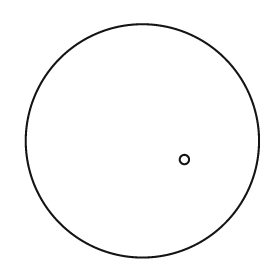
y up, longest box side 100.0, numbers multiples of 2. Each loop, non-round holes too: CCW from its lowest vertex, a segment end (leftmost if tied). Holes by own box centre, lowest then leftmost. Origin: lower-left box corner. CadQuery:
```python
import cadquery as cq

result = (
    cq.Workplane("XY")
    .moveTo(50.0, 50.0)
    .circle(50.0)
    .moveTo(68.0, 42.0)
    .circle(2.0)
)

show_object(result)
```